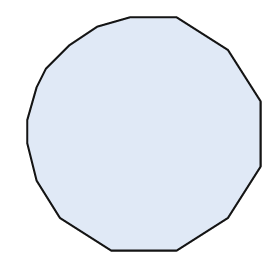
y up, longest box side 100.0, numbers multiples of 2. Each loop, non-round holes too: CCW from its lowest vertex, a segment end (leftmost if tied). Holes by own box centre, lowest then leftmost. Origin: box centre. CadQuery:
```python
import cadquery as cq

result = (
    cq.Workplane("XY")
    .moveTo(-14.0, -50.0)
    .lineTo(14.0, -50.0)
    .lineTo(36.0, -36.0)
    .lineTo(50.0, -14.0)
    .lineTo(50.0, 14.0)
    .lineTo(36.0, 36.0)
    .lineTo(14.0, 50.0)
    .lineTo(-6.0, 50.0)
    .lineTo(-20.0, 46.0)
    .lineTo(-32.0, 38.0)
    .lineTo(-42.0, 28.0)
    .lineTo(-46.0, 20.0)
    .lineTo(-50.0, 6.0)
    .lineTo(-50.0, -4.0)
    .lineTo(-46.0, -20.0)
    .lineTo(-36.0, -36.0)
    .close()
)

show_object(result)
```